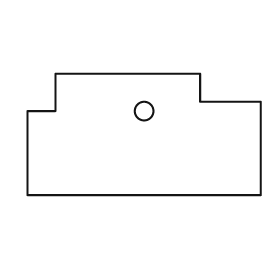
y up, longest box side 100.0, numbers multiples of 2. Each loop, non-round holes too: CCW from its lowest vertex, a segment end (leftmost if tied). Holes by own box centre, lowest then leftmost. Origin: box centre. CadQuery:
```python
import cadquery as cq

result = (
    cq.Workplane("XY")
    .moveTo(-50.0, -26.0)
    .lineTo(50.0, -26.0)
    .lineTo(50.0, 14.0)
    .lineTo(24.0, 14.0)
    .lineTo(24.0, 26.0)
    .lineTo(-38.0, 26.0)
    .lineTo(-38.0, 10.0)
    .lineTo(-50.0, 10.0)
    .close()
    .moveTo(0.0, 10.0)
    .circle(4.0)
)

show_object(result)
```